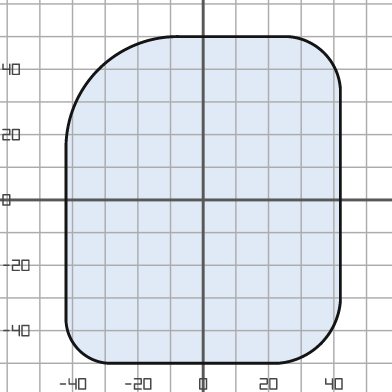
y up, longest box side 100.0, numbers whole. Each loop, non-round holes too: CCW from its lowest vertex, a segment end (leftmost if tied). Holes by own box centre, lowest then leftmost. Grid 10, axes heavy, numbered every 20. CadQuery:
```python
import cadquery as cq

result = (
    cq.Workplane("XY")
    .moveTo(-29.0, -50.0)
    .lineTo(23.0, -50.0)
    .threePointArc((36.0, -44.0), (42.0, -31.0))
    .lineTo(42.0, 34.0)
    .threePointArc((37.0, 45.0), (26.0, 50.0))
    .lineTo(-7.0, 50.0)
    .threePointArc((-32.0, 40.0), (-42.0, 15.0))
    .lineTo(-42.0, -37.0)
    .threePointArc((-38.0, -46.0), (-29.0, -50.0))
    .close()
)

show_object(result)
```